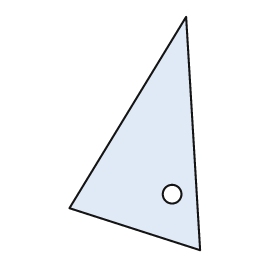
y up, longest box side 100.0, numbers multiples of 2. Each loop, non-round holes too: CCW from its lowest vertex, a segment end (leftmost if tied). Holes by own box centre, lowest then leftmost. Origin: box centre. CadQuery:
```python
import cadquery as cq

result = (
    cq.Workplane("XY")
    .moveTo(28.0, -50.0)
    .lineTo(22.0, 50.0)
    .lineTo(-28.0, -32.0)
    .close()
    .moveTo(16.0, -26.0)
    .circle(4.0)
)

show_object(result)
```